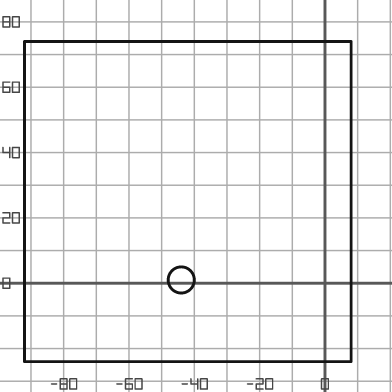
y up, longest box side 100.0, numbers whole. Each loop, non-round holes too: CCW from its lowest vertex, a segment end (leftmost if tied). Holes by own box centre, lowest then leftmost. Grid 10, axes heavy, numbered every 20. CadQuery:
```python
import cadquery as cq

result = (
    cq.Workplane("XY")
    .moveTo(-92.0, -24.0)
    .lineTo(8.0, -24.0)
    .lineTo(8.0, 74.0)
    .lineTo(-92.0, 74.0)
    .close()
    .moveTo(-44.0, 1.0)
    .circle(4.0)
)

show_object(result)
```